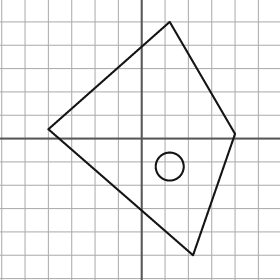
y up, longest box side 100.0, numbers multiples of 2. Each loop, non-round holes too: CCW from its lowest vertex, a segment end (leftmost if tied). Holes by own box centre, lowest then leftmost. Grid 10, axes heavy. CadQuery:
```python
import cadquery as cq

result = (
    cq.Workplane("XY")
    .moveTo(22.0, -50.0)
    .lineTo(40.0, 2.0)
    .lineTo(12.0, 50.0)
    .lineTo(-40.0, 4.0)
    .close()
    .moveTo(12.0, -12.0)
    .circle(6.0)
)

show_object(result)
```